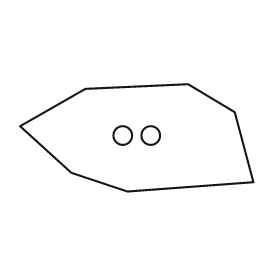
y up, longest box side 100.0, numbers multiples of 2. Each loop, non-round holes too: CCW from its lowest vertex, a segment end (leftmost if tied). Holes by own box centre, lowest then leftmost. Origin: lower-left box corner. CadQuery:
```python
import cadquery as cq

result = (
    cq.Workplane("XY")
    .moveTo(46.0, 0.0)
    .lineTo(100.0, 4.0)
    .lineTo(92.0, 34.0)
    .lineTo(72.0, 46.0)
    .lineTo(28.0, 44.0)
    .lineTo(0.0, 28.0)
    .lineTo(22.0, 8.0)
    .close()
    .moveTo(44.0, 24.0)
    .circle(4.0)
    .moveTo(56.0, 24.0)
    .circle(4.0)
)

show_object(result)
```